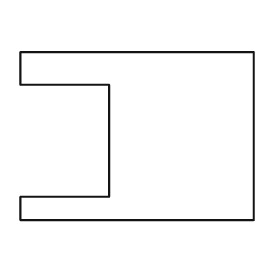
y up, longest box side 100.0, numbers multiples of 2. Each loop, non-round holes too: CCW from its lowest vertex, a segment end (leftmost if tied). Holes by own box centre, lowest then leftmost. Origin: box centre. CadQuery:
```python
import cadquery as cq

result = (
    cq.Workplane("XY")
    .moveTo(-50.0, -36.0)
    .lineTo(50.0, -36.0)
    .lineTo(50.0, 36.0)
    .lineTo(-50.0, 36.0)
    .lineTo(-50.0, 22.0)
    .lineTo(-12.0, 22.0)
    .lineTo(-12.0, -26.0)
    .lineTo(-50.0, -26.0)
    .close()
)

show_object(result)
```